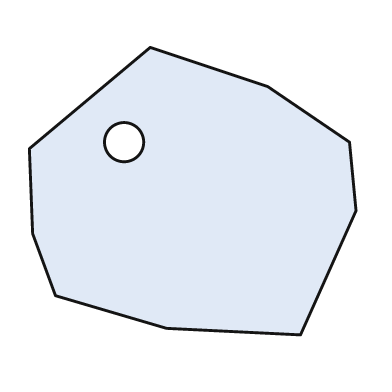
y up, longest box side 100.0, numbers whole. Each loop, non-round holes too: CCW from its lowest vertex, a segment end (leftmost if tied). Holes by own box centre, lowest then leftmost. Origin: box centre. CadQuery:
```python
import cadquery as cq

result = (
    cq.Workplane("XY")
    .moveTo(33.0, -44.0)
    .lineTo(50.0, -6.0)
    .lineTo(48.0, 15.0)
    .lineTo(23.0, 32.0)
    .lineTo(-13.0, 44.0)
    .lineTo(-50.0, 13.0)
    .lineTo(-49.0, -13.0)
    .lineTo(-42.0, -32.0)
    .lineTo(-8.0, -42.0)
    .close()
    .moveTo(-21.0, 15.0)
    .circle(6.0)
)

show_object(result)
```